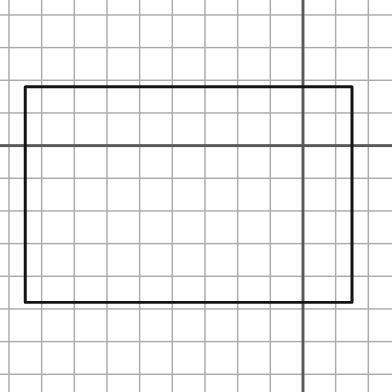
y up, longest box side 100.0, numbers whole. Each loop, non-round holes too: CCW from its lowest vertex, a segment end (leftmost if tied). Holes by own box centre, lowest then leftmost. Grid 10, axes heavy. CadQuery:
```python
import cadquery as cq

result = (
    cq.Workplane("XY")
    .moveTo(-85.0, -48.0)
    .lineTo(15.0, -48.0)
    .lineTo(15.0, 18.0)
    .lineTo(-85.0, 18.0)
    .close()
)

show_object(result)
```